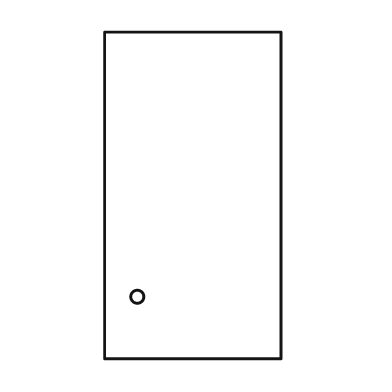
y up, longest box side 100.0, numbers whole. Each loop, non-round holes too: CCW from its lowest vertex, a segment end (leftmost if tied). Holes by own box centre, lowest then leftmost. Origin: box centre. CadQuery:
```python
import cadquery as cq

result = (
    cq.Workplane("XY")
    .moveTo(-27.0, -50.0)
    .lineTo(27.0, -50.0)
    .lineTo(27.0, 50.0)
    .lineTo(-27.0, 50.0)
    .close()
    .moveTo(-17.0, -31.0)
    .circle(2.0)
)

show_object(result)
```